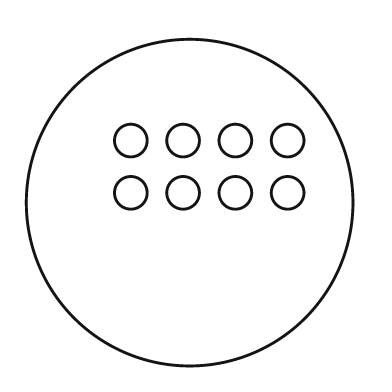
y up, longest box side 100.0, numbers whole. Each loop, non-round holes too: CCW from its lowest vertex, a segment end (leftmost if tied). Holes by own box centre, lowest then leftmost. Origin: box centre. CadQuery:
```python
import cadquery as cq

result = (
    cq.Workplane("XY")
    .moveTo(0.0, 0.0)
    .circle(50.0)
    .moveTo(-18.0, 3.0)
    .circle(5.0)
    .moveTo(-2.0, 3.0)
    .circle(5.0)
    .moveTo(14.0, 3.0)
    .circle(5.0)
    .moveTo(30.0, 3.0)
    .circle(5.0)
    .moveTo(-18.0, 19.0)
    .circle(5.0)
    .moveTo(-2.0, 19.0)
    .circle(5.0)
    .moveTo(14.0, 19.0)
    .circle(5.0)
    .moveTo(30.0, 19.0)
    .circle(5.0)
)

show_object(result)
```